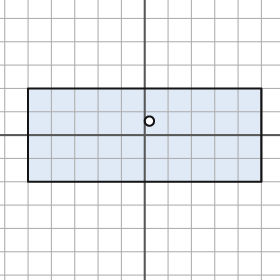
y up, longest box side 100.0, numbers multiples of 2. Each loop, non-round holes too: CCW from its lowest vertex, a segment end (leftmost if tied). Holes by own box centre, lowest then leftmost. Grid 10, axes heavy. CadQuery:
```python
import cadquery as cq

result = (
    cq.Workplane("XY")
    .moveTo(-50.0, -20.0)
    .lineTo(50.0, -20.0)
    .lineTo(50.0, 20.0)
    .lineTo(-50.0, 20.0)
    .close()
    .moveTo(2.0, 6.0)
    .circle(2.0)
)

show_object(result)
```